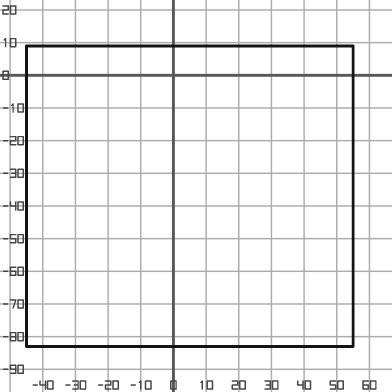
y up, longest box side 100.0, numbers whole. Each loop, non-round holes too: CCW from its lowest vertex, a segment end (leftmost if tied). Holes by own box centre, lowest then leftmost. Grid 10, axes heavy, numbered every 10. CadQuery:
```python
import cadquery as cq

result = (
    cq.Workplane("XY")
    .moveTo(-45.0, -83.0)
    .lineTo(55.0, -83.0)
    .lineTo(55.0, 9.0)
    .lineTo(-45.0, 9.0)
    .close()
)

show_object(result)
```